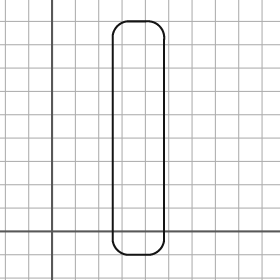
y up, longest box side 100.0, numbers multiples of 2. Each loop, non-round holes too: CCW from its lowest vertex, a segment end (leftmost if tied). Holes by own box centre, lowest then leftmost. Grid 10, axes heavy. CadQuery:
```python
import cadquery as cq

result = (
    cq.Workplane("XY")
    .moveTo(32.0, -10.0)
    .lineTo(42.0, -10.0)
    .threePointArc((46.0, -8.0), (48.0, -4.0))
    .lineTo(48.0, 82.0)
    .threePointArc((46.0, 88.0), (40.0, 90.0))
    .lineTo(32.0, 90.0)
    .threePointArc((28.0, 88.0), (26.0, 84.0))
    .lineTo(26.0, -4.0)
    .threePointArc((28.0, -8.0), (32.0, -10.0))
    .close()
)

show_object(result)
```